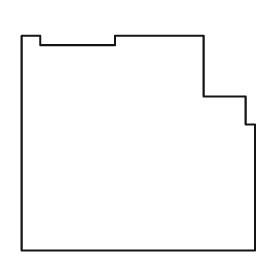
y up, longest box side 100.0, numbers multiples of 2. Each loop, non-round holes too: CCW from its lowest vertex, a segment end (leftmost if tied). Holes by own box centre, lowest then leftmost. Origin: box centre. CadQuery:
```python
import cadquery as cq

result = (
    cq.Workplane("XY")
    .moveTo(-50.0, -46.0)
    .lineTo(50.0, -46.0)
    .lineTo(50.0, 8.0)
    .lineTo(46.0, 8.0)
    .lineTo(46.0, 20.0)
    .lineTo(28.0, 20.0)
    .lineTo(28.0, 46.0)
    .lineTo(-10.0, 46.0)
    .lineTo(-10.0, 42.0)
    .lineTo(-42.0, 42.0)
    .lineTo(-42.0, 46.0)
    .lineTo(-50.0, 46.0)
    .close()
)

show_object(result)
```